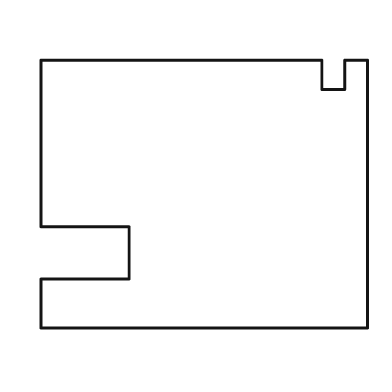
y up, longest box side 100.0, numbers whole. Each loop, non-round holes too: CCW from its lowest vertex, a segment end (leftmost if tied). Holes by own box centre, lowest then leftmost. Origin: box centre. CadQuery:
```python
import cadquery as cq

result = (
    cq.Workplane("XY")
    .moveTo(-50.0, -41.0)
    .lineTo(50.0, -41.0)
    .lineTo(50.0, 41.0)
    .lineTo(43.0, 41.0)
    .lineTo(43.0, 32.0)
    .lineTo(36.0, 32.0)
    .lineTo(36.0, 41.0)
    .lineTo(-50.0, 41.0)
    .lineTo(-50.0, -10.0)
    .lineTo(-23.0, -10.0)
    .lineTo(-23.0, -26.0)
    .lineTo(-50.0, -26.0)
    .close()
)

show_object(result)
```